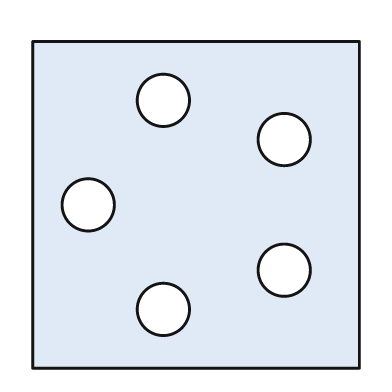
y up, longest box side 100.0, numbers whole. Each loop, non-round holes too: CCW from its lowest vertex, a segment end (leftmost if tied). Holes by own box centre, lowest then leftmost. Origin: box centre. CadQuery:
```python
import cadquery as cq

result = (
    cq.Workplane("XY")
    .moveTo(-50.0, -50.0)
    .lineTo(50.0, -50.0)
    .lineTo(50.0, 50.0)
    .lineTo(-50.0, 50.0)
    .close()
    .moveTo(-10.0, -32.0)
    .circle(8.0)
    .moveTo(27.0, -20.0)
    .circle(8.0)
    .moveTo(-33.0, 0.0)
    .circle(8.0)
    .moveTo(27.0, 20.0)
    .circle(8.0)
    .moveTo(-10.0, 32.0)
    .circle(8.0)
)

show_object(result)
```